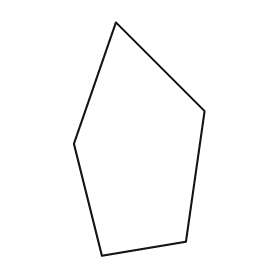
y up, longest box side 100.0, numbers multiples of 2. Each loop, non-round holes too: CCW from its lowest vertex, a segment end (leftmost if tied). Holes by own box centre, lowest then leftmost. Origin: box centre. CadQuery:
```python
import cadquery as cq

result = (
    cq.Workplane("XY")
    .moveTo(-16.0, -50.0)
    .lineTo(20.0, -44.0)
    .lineTo(28.0, 12.0)
    .lineTo(-10.0, 50.0)
    .lineTo(-28.0, -2.0)
    .close()
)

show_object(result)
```